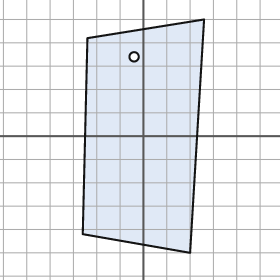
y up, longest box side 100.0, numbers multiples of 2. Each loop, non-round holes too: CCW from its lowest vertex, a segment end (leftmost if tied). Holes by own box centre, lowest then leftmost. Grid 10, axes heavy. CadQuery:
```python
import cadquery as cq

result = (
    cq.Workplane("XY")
    .moveTo(20.0, -50.0)
    .lineTo(26.0, 50.0)
    .lineTo(-24.0, 42.0)
    .lineTo(-26.0, -42.0)
    .close()
    .moveTo(-4.0, 34.0)
    .circle(2.0)
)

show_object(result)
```